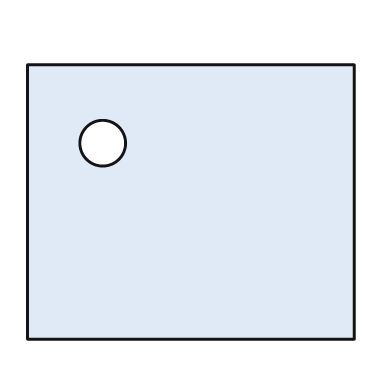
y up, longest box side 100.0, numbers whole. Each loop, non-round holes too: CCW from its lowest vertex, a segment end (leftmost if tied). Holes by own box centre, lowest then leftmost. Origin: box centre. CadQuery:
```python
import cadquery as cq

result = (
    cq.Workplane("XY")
    .moveTo(-50.0, -42.0)
    .lineTo(50.0, -42.0)
    .lineTo(50.0, 42.0)
    .lineTo(-50.0, 42.0)
    .close()
    .moveTo(-27.0, 18.0)
    .circle(7.0)
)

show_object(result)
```